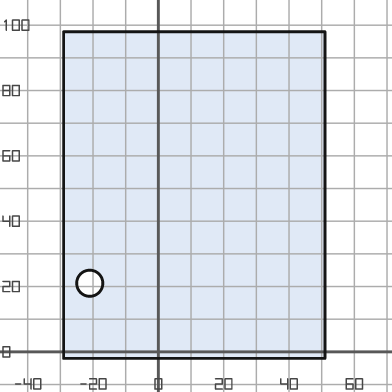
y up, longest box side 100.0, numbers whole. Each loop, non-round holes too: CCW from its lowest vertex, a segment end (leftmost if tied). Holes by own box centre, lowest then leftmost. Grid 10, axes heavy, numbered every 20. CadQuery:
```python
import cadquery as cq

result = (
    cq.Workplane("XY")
    .moveTo(-29.0, -2.0)
    .lineTo(51.0, -2.0)
    .lineTo(51.0, 98.0)
    .lineTo(-29.0, 98.0)
    .close()
    .moveTo(-21.0, 21.0)
    .circle(4.0)
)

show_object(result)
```